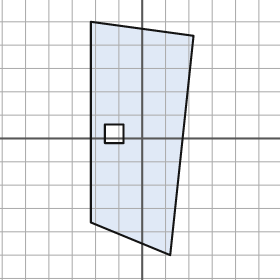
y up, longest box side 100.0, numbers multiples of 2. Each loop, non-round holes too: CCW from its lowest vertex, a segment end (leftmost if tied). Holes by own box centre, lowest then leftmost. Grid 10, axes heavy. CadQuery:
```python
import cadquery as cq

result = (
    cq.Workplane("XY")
    .moveTo(12.0, -50.0)
    .lineTo(22.0, 44.0)
    .lineTo(-22.0, 50.0)
    .lineTo(-22.0, -36.0)
    .close()
    .moveTo(-16.0, -2.0)
    .lineTo(-8.0, -2.0)
    .lineTo(-8.0, 6.0)
    .lineTo(-16.0, 6.0)
    .close()
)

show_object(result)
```